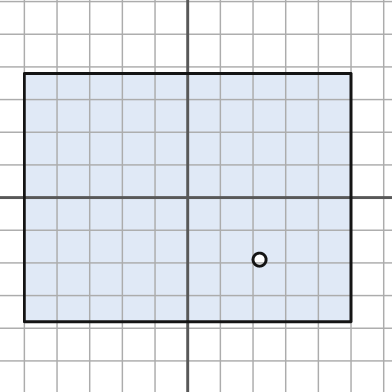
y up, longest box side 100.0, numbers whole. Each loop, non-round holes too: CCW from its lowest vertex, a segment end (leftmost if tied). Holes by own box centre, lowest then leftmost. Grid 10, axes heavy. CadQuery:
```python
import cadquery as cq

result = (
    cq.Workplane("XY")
    .moveTo(-50.0, -38.0)
    .lineTo(50.0, -38.0)
    .lineTo(50.0, 38.0)
    .lineTo(-50.0, 38.0)
    .close()
    .moveTo(22.0, -19.0)
    .circle(2.0)
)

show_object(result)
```